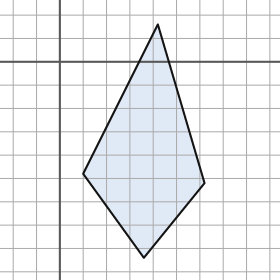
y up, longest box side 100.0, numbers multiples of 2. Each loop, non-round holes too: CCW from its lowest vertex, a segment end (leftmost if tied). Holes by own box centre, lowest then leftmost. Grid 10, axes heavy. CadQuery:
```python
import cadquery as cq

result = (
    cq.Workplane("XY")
    .moveTo(36.0, -84.0)
    .lineTo(62.0, -52.0)
    .lineTo(42.0, 16.0)
    .lineTo(10.0, -48.0)
    .close()
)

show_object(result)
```